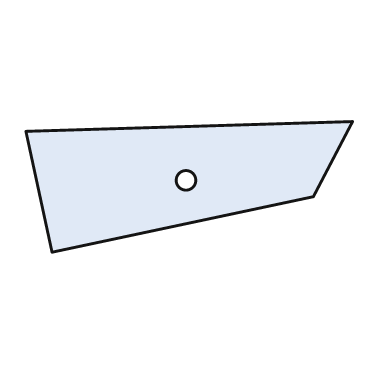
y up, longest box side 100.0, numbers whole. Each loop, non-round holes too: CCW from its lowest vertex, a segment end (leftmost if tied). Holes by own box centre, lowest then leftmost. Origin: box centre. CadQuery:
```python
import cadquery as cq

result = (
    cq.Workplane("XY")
    .moveTo(-42.0, -20.0)
    .lineTo(38.0, -3.0)
    .lineTo(50.0, 20.0)
    .lineTo(-50.0, 17.0)
    .close()
    .moveTo(-1.0, 2.0)
    .circle(3.0)
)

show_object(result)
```